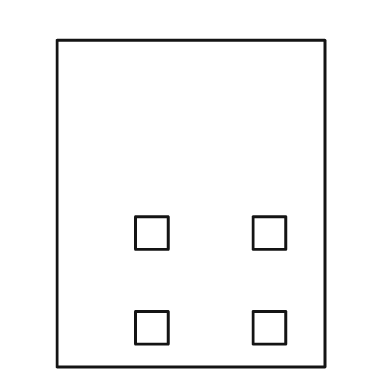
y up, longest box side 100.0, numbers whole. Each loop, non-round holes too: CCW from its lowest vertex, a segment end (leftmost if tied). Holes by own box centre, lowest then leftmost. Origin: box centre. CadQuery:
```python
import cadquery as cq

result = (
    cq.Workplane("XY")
    .moveTo(-41.0, -50.0)
    .lineTo(41.0, -50.0)
    .lineTo(41.0, 50.0)
    .lineTo(-41.0, 50.0)
    .close()
    .moveTo(-17.0, -43.0)
    .lineTo(-7.0, -43.0)
    .lineTo(-7.0, -33.0)
    .lineTo(-17.0, -33.0)
    .close()
    .moveTo(19.0, -43.0)
    .lineTo(29.0, -43.0)
    .lineTo(29.0, -33.0)
    .lineTo(19.0, -33.0)
    .close()
    .moveTo(-17.0, -14.0)
    .lineTo(-7.0, -14.0)
    .lineTo(-7.0, -4.0)
    .lineTo(-17.0, -4.0)
    .close()
    .moveTo(19.0, -14.0)
    .lineTo(29.0, -14.0)
    .lineTo(29.0, -4.0)
    .lineTo(19.0, -4.0)
    .close()
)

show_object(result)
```